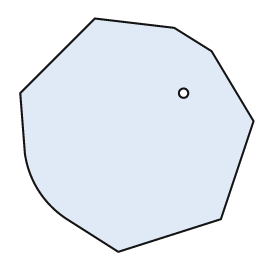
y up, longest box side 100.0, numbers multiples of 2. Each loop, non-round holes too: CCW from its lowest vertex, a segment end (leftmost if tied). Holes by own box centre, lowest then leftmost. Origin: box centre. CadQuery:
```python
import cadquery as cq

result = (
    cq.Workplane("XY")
    .moveTo(-8.0, -50.0)
    .lineTo(36.0, -36.0)
    .lineTo(50.0, 6.0)
    .lineTo(32.0, 36.0)
    .lineTo(16.0, 46.0)
    .lineTo(-18.0, 50.0)
    .lineTo(-50.0, 18.0)
    .lineTo(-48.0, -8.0)
    .threePointArc((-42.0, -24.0), (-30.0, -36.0))
    .close()
    .moveTo(20.0, 18.0)
    .circle(2.0)
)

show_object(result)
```